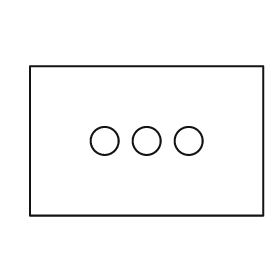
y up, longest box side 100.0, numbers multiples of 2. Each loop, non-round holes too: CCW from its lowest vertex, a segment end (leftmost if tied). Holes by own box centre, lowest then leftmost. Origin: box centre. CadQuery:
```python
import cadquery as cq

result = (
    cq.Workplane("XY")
    .moveTo(-50.0, -32.0)
    .lineTo(50.0, -32.0)
    .lineTo(50.0, 32.0)
    .lineTo(-50.0, 32.0)
    .close()
    .moveTo(-18.0, 0.0)
    .circle(6.0)
    .moveTo(0.0, 0.0)
    .circle(6.0)
    .moveTo(18.0, 0.0)
    .circle(6.0)
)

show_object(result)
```